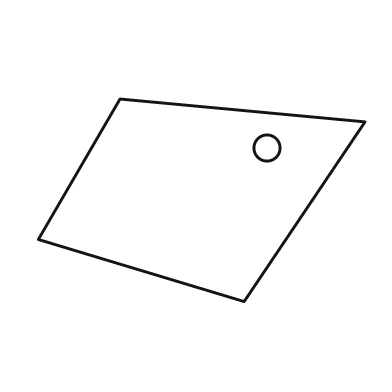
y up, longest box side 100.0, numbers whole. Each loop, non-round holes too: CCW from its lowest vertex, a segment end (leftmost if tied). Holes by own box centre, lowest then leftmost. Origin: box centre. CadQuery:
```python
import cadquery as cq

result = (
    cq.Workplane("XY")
    .moveTo(13.0, -31.0)
    .lineTo(50.0, 24.0)
    .lineTo(-25.0, 31.0)
    .lineTo(-50.0, -12.0)
    .close()
    .moveTo(20.0, 16.0)
    .circle(4.0)
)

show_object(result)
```